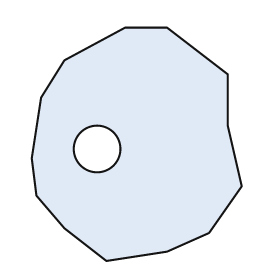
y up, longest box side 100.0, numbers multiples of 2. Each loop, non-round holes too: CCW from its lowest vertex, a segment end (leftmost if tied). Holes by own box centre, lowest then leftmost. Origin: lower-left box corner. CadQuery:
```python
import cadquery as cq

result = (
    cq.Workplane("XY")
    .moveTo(32.0, 0.0)
    .lineTo(58.0, 4.0)
    .lineTo(76.0, 12.0)
    .lineTo(90.0, 32.0)
    .lineTo(84.0, 58.0)
    .lineTo(84.0, 80.0)
    .lineTo(58.0, 100.0)
    .lineTo(40.0, 100.0)
    .lineTo(14.0, 86.0)
    .lineTo(4.0, 70.0)
    .lineTo(0.0, 44.0)
    .lineTo(2.0, 28.0)
    .lineTo(14.0, 14.0)
    .close()
    .moveTo(28.0, 48.0)
    .circle(10.0)
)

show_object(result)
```